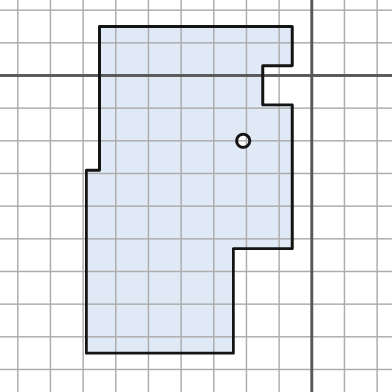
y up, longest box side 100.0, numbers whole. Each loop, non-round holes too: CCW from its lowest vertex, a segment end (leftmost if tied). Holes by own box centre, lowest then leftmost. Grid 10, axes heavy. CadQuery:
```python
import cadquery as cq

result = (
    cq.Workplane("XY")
    .moveTo(-69.0, -85.0)
    .lineTo(-24.0, -85.0)
    .lineTo(-24.0, -53.0)
    .lineTo(-6.0, -53.0)
    .lineTo(-6.0, -9.0)
    .lineTo(-15.0, -9.0)
    .lineTo(-15.0, 3.0)
    .lineTo(-6.0, 3.0)
    .lineTo(-6.0, 15.0)
    .lineTo(-65.0, 15.0)
    .lineTo(-65.0, -29.0)
    .lineTo(-69.0, -29.0)
    .close()
    .moveTo(-21.0, -20.0)
    .circle(2.0)
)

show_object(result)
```